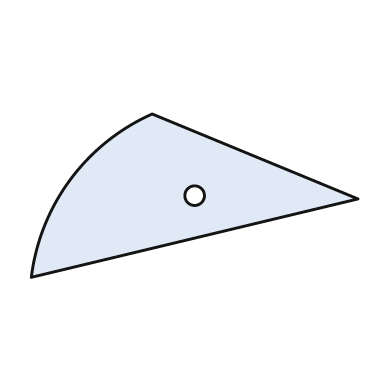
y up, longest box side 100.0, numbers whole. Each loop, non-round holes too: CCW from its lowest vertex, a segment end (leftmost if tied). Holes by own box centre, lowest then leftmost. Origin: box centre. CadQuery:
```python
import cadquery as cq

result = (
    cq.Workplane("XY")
    .moveTo(-50.0, -25.0)
    .lineTo(50.0, -1.0)
    .lineTo(-13.0, 25.0)
    .threePointArc((-38.0, 5.0), (-50.0, -25.0))
    .close()
    .moveTo(0.0, 0.0)
    .circle(3.0)
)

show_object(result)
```